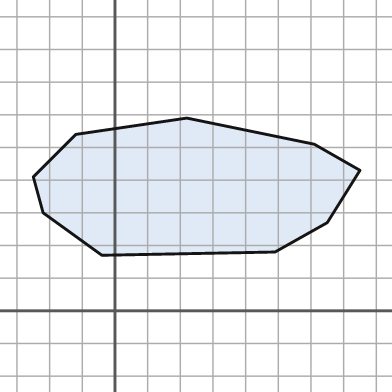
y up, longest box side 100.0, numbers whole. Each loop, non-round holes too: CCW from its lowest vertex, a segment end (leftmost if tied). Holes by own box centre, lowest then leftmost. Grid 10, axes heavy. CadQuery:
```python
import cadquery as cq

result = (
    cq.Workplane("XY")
    .moveTo(-4.0, 17.0)
    .lineTo(49.0, 18.0)
    .lineTo(65.0, 27.0)
    .lineTo(75.0, 43.0)
    .lineTo(61.0, 51.0)
    .lineTo(22.0, 59.0)
    .lineTo(-12.0, 54.0)
    .lineTo(-25.0, 41.0)
    .lineTo(-22.0, 30.0)
    .close()
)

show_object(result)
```